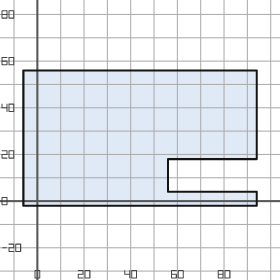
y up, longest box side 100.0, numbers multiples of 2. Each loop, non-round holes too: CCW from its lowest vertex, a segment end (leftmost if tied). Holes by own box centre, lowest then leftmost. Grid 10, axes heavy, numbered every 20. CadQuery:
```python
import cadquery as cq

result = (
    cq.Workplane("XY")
    .moveTo(-6.0, -2.0)
    .lineTo(94.0, -2.0)
    .lineTo(94.0, 4.0)
    .lineTo(56.0, 4.0)
    .lineTo(56.0, 18.0)
    .lineTo(94.0, 18.0)
    .lineTo(94.0, 56.0)
    .lineTo(-6.0, 56.0)
    .close()
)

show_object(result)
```